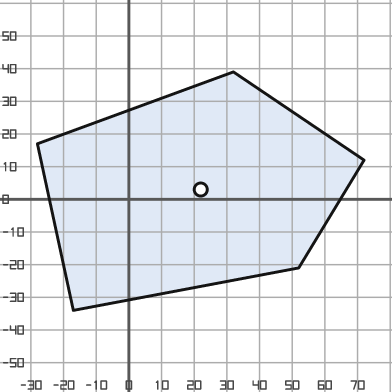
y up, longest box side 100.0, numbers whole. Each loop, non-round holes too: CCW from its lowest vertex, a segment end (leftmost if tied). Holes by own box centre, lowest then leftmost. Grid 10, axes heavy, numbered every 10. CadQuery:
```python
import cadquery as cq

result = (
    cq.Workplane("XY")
    .moveTo(-17.0, -34.0)
    .lineTo(52.0, -21.0)
    .lineTo(72.0, 12.0)
    .lineTo(32.0, 39.0)
    .lineTo(-28.0, 17.0)
    .close()
    .moveTo(22.0, 3.0)
    .circle(2.0)
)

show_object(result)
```